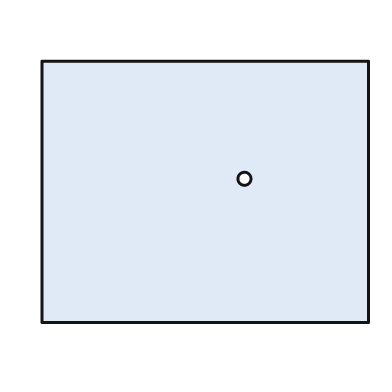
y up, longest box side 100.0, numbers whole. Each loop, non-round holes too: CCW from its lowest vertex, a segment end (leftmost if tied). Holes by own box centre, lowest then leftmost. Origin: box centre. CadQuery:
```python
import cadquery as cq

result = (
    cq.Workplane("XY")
    .moveTo(-50.0, -40.0)
    .lineTo(50.0, -40.0)
    .lineTo(50.0, 40.0)
    .lineTo(-50.0, 40.0)
    .close()
    .moveTo(12.0, 4.0)
    .circle(2.0)
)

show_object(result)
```